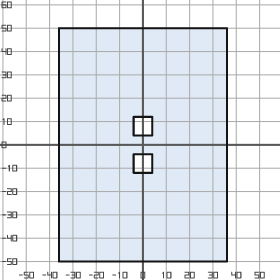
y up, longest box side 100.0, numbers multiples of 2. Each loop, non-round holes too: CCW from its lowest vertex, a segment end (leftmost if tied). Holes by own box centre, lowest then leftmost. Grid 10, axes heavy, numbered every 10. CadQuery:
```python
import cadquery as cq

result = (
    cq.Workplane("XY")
    .moveTo(-36.0, -50.0)
    .lineTo(36.0, -50.0)
    .lineTo(36.0, 50.0)
    .lineTo(-36.0, 50.0)
    .close()
    .moveTo(-4.0, -12.0)
    .lineTo(4.0, -12.0)
    .lineTo(4.0, -4.0)
    .lineTo(-4.0, -4.0)
    .close()
    .moveTo(-4.0, 4.0)
    .lineTo(4.0, 4.0)
    .lineTo(4.0, 12.0)
    .lineTo(-4.0, 12.0)
    .close()
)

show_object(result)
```